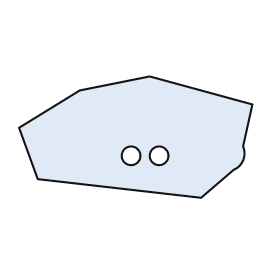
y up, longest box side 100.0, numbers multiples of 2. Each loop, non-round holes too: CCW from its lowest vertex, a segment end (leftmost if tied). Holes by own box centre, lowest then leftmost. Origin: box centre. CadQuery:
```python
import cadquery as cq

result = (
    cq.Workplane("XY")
    .moveTo(28.0, -26.0)
    .lineTo(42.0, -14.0)
    .threePointArc((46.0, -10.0), (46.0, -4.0))
    .lineTo(50.0, 14.0)
    .lineTo(6.0, 26.0)
    .lineTo(-24.0, 20.0)
    .lineTo(-50.0, 4.0)
    .lineTo(-42.0, -18.0)
    .close()
    .moveTo(-2.0, -8.0)
    .circle(4.0)
    .moveTo(10.0, -8.0)
    .circle(4.0)
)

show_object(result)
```